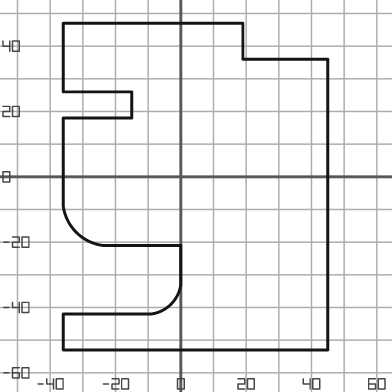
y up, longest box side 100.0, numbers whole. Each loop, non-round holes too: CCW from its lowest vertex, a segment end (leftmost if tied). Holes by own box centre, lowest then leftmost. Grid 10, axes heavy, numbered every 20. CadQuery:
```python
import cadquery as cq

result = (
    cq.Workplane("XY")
    .moveTo(-36.0, -53.0)
    .lineTo(45.0, -53.0)
    .lineTo(45.0, 36.0)
    .lineTo(19.0, 36.0)
    .lineTo(19.0, 47.0)
    .lineTo(-36.0, 47.0)
    .lineTo(-36.0, 26.0)
    .lineTo(-15.0, 26.0)
    .lineTo(-15.0, 18.0)
    .lineTo(-36.0, 18.0)
    .lineTo(-36.0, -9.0)
    .threePointArc((-32.0, -17.0), (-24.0, -21.0))
    .lineTo(0.0, -21.0)
    .lineTo(0.0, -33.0)
    .threePointArc((-3.0, -39.0), (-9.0, -42.0))
    .lineTo(-36.0, -42.0)
    .close()
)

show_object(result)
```